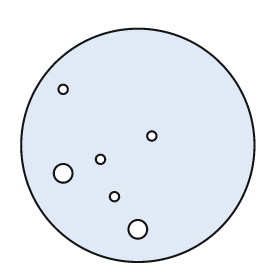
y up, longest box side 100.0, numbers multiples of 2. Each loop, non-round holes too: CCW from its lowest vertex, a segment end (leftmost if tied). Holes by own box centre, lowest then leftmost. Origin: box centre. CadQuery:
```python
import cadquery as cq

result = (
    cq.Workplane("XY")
    .moveTo(0.0, 0.0)
    .circle(50.0)
    .moveTo(0.0, -36.0)
    .circle(4.0)
    .moveTo(-10.0, -22.0)
    .circle(2.0)
    .moveTo(-32.0, -12.0)
    .circle(4.0)
    .moveTo(-16.0, -6.0)
    .circle(2.0)
    .moveTo(6.0, 4.0)
    .circle(2.0)
    .moveTo(-32.0, 24.0)
    .circle(2.0)
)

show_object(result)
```